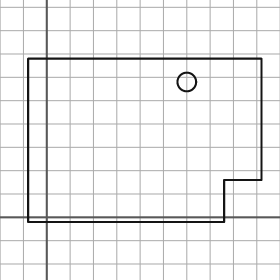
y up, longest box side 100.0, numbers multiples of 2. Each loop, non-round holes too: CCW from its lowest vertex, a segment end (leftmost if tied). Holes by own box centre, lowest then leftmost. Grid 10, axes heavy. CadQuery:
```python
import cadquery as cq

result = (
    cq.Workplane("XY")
    .moveTo(-8.0, -2.0)
    .lineTo(76.0, -2.0)
    .lineTo(76.0, 16.0)
    .lineTo(92.0, 16.0)
    .lineTo(92.0, 68.0)
    .lineTo(-8.0, 68.0)
    .close()
    .moveTo(60.0, 58.0)
    .circle(4.0)
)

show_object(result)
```